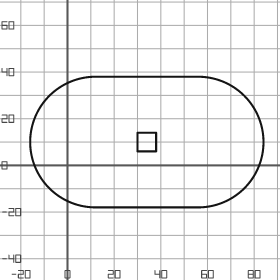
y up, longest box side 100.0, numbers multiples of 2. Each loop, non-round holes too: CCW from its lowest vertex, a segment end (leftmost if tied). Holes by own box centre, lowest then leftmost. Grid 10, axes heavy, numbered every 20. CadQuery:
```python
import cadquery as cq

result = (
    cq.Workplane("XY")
    .moveTo(12.0, -18.0)
    .lineTo(56.0, -18.0)
    .threePointArc((84.0, 10.0), (56.0, 38.0))
    .lineTo(12.0, 38.0)
    .threePointArc((-16.0, 10.0), (12.0, -18.0))
    .close()
    .moveTo(30.0, 6.0)
    .lineTo(38.0, 6.0)
    .lineTo(38.0, 14.0)
    .lineTo(30.0, 14.0)
    .close()
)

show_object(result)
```